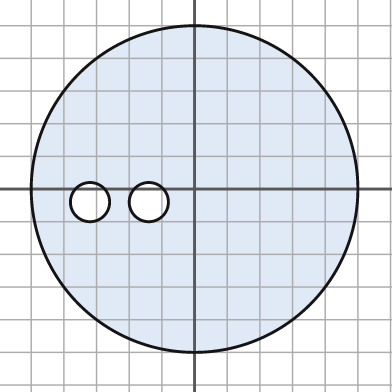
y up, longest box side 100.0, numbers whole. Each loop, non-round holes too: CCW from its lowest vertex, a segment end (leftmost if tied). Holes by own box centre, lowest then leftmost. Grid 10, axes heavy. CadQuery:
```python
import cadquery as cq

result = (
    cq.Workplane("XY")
    .moveTo(0.0, 0.0)
    .circle(50.0)
    .moveTo(-32.0, -4.0)
    .circle(6.0)
    .moveTo(-14.0, -4.0)
    .circle(6.0)
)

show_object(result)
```